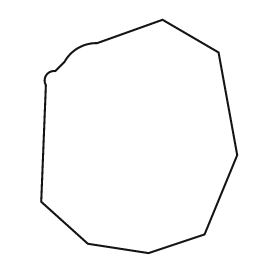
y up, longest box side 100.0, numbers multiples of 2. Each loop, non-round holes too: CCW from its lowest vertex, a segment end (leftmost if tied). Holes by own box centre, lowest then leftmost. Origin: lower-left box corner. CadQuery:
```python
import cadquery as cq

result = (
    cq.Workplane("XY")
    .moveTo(46.0, 0.0)
    .lineTo(70.0, 8.0)
    .lineTo(84.0, 42.0)
    .lineTo(76.0, 86.0)
    .lineTo(52.0, 100.0)
    .lineTo(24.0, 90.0)
    .threePointArc((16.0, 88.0), (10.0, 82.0))
    .lineTo(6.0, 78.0)
    .threePointArc((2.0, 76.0), (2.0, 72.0))
    .lineTo(0.0, 22.0)
    .lineTo(20.0, 4.0)
    .close()
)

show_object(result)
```